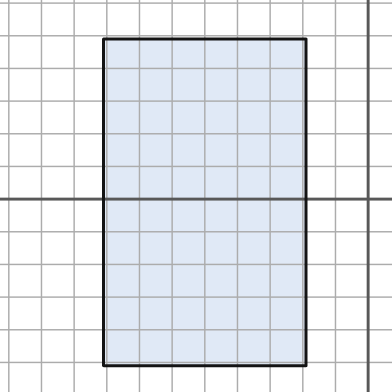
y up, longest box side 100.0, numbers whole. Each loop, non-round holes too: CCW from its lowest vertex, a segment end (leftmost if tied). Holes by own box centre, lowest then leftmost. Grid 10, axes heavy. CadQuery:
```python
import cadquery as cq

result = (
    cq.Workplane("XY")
    .moveTo(-81.0, -51.0)
    .lineTo(-19.0, -51.0)
    .lineTo(-19.0, 49.0)
    .lineTo(-81.0, 49.0)
    .close()
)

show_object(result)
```